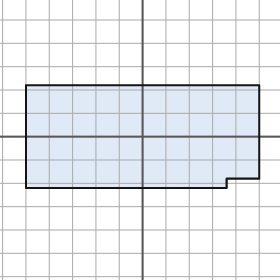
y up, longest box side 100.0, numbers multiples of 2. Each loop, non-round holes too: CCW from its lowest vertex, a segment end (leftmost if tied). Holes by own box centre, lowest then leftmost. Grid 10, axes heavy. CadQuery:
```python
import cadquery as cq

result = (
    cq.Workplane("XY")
    .moveTo(-50.0, -22.0)
    .lineTo(36.0, -22.0)
    .lineTo(36.0, -18.0)
    .lineTo(50.0, -18.0)
    .lineTo(50.0, 22.0)
    .lineTo(-50.0, 22.0)
    .close()
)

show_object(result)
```